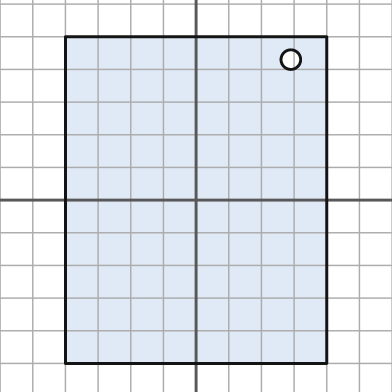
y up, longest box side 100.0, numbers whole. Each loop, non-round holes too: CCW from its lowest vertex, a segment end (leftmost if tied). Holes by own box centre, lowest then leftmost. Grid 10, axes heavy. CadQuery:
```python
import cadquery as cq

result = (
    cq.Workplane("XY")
    .moveTo(-40.0, -50.0)
    .lineTo(40.0, -50.0)
    .lineTo(40.0, 50.0)
    .lineTo(-40.0, 50.0)
    .close()
    .moveTo(29.0, 43.0)
    .circle(3.0)
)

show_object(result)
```